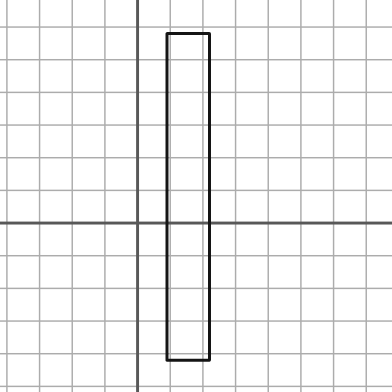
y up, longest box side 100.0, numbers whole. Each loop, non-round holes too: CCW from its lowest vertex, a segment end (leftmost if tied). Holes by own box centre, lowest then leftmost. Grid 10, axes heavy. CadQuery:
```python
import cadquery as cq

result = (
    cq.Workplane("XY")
    .moveTo(9.0, -42.0)
    .lineTo(22.0, -42.0)
    .lineTo(22.0, 58.0)
    .lineTo(9.0, 58.0)
    .close()
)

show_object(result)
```